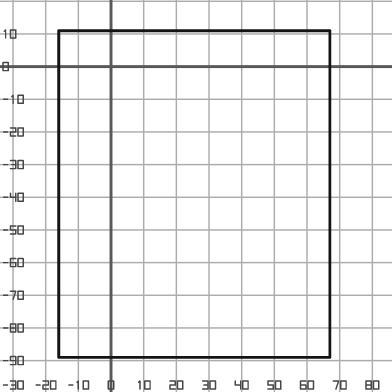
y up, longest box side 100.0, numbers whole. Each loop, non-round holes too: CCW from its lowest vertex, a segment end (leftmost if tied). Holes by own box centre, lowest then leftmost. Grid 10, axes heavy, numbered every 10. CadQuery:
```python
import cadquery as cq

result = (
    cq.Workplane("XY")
    .moveTo(-16.0, -89.0)
    .lineTo(67.0, -89.0)
    .lineTo(67.0, 11.0)
    .lineTo(-16.0, 11.0)
    .close()
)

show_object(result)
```